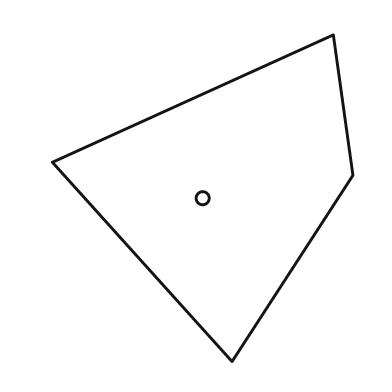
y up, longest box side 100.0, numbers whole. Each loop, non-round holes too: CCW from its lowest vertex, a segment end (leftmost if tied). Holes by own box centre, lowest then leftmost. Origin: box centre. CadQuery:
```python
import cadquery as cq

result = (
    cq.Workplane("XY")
    .moveTo(9.0, -50.0)
    .lineTo(46.0, 7.0)
    .lineTo(40.0, 50.0)
    .lineTo(-46.0, 11.0)
    .close()
    .moveTo(0.0, 0.0)
    .circle(2.0)
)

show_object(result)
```